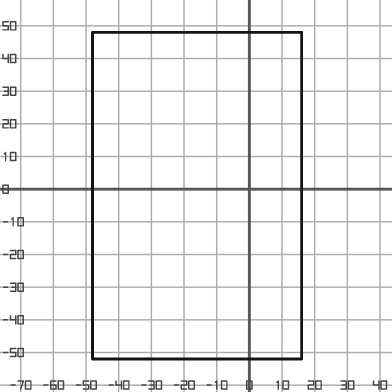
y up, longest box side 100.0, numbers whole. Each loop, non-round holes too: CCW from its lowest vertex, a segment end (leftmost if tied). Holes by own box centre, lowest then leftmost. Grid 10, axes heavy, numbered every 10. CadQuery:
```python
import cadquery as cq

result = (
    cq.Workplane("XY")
    .moveTo(-48.0, -52.0)
    .lineTo(16.0, -52.0)
    .lineTo(16.0, 48.0)
    .lineTo(-48.0, 48.0)
    .close()
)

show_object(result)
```